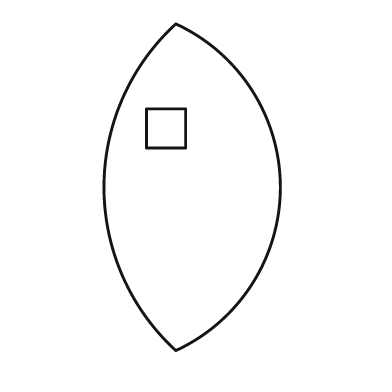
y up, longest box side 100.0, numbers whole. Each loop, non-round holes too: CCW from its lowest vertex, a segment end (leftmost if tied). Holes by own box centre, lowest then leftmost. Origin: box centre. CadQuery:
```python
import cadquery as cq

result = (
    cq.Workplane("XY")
    .moveTo(-5.0, -50.0)
    .threePointArc((27.0, 0.0), (-5.0, 50.0))
    .threePointArc((-27.0, 0.0), (-5.0, -50.0))
    .close()
    .moveTo(-14.0, 12.0)
    .lineTo(-2.0, 12.0)
    .lineTo(-2.0, 24.0)
    .lineTo(-14.0, 24.0)
    .close()
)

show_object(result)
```